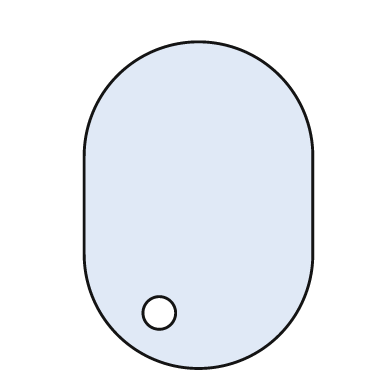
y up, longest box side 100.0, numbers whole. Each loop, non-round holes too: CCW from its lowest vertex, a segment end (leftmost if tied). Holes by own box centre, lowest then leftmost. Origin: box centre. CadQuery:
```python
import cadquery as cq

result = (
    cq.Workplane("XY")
    .moveTo(-35.0, -15.0)
    .threePointArc((0.0, -50.0), (35.0, -15.0))
    .lineTo(35.0, 15.0)
    .threePointArc((0.0, 50.0), (-35.0, 15.0))
    .close()
    .moveTo(-12.0, -33.0)
    .circle(5.0)
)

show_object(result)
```